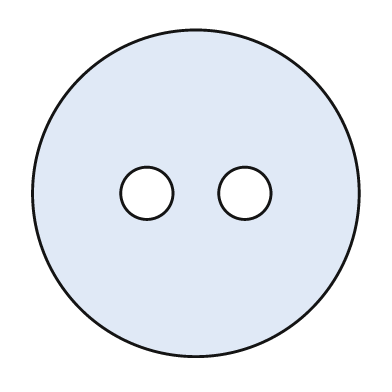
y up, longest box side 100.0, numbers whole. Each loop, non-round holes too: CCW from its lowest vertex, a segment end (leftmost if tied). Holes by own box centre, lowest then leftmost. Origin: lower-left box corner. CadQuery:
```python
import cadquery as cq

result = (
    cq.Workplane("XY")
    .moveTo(50.0, 50.0)
    .circle(50.0)
    .moveTo(35.0, 50.0)
    .circle(8.0)
    .moveTo(65.0, 50.0)
    .circle(8.0)
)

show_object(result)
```